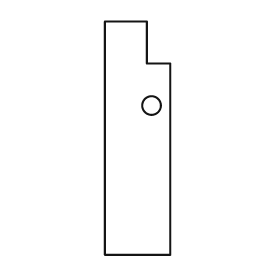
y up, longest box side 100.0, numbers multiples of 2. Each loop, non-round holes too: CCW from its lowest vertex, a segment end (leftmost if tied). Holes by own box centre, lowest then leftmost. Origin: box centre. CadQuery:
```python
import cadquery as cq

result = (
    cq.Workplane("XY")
    .moveTo(-14.0, -50.0)
    .lineTo(14.0, -50.0)
    .lineTo(14.0, 32.0)
    .lineTo(4.0, 32.0)
    .lineTo(4.0, 50.0)
    .lineTo(-14.0, 50.0)
    .close()
    .moveTo(6.0, 14.0)
    .circle(4.0)
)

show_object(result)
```